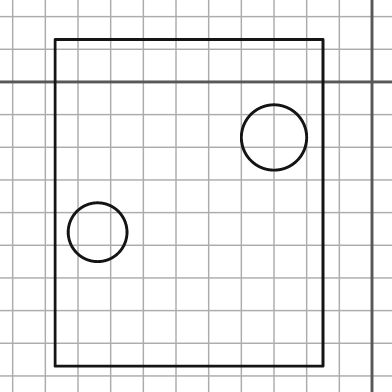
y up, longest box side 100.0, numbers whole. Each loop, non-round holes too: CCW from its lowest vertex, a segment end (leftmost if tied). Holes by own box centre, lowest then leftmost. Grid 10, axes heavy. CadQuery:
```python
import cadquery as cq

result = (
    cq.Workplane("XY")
    .moveTo(-97.0, -87.0)
    .lineTo(-15.0, -87.0)
    .lineTo(-15.0, 13.0)
    .lineTo(-97.0, 13.0)
    .close()
    .moveTo(-84.0, -46.0)
    .circle(9.0)
    .moveTo(-30.0, -17.0)
    .circle(10.0)
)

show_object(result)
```